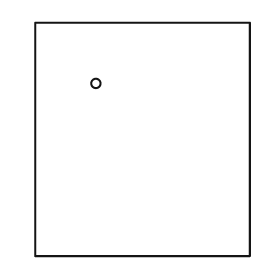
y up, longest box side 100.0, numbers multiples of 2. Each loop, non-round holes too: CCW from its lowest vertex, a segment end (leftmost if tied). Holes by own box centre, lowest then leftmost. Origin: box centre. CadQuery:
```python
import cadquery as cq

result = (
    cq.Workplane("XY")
    .moveTo(-46.0, -50.0)
    .lineTo(46.0, -50.0)
    .lineTo(46.0, 50.0)
    .lineTo(-46.0, 50.0)
    .close()
    .moveTo(-20.0, 24.0)
    .circle(2.0)
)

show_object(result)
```